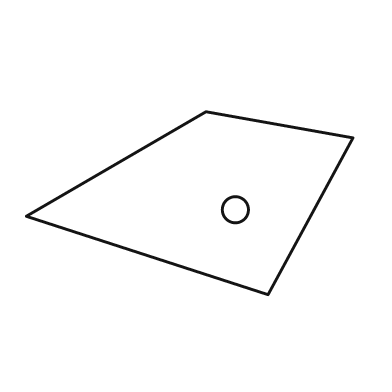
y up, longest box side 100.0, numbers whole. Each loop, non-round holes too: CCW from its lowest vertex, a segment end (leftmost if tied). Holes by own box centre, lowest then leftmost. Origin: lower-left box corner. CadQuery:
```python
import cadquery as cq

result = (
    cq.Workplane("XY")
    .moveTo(74.0, 0.0)
    .lineTo(100.0, 48.0)
    .lineTo(55.0, 56.0)
    .lineTo(0.0, 24.0)
    .close()
    .moveTo(64.0, 26.0)
    .circle(4.0)
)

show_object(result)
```